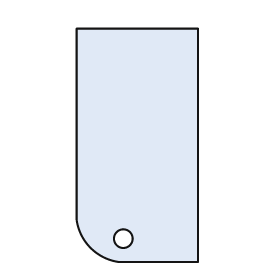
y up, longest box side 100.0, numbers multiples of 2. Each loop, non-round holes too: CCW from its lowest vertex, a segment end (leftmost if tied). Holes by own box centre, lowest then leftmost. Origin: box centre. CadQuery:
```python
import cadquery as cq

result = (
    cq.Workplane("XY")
    .moveTo(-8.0, -50.0)
    .lineTo(26.0, -50.0)
    .lineTo(26.0, 50.0)
    .lineTo(-26.0, 50.0)
    .lineTo(-26.0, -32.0)
    .threePointArc((-20.0, -44.0), (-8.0, -50.0))
    .close()
    .moveTo(-6.0, -40.0)
    .circle(4.0)
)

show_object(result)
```